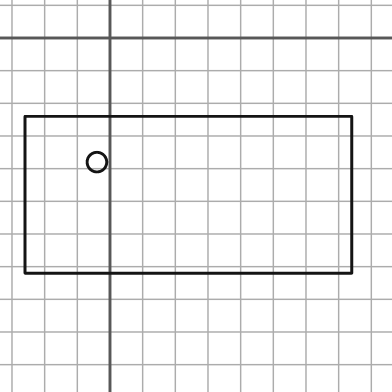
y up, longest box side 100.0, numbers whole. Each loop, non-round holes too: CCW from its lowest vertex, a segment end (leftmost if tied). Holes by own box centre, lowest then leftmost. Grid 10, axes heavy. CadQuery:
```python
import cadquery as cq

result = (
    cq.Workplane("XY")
    .moveTo(-26.0, -72.0)
    .lineTo(74.0, -72.0)
    .lineTo(74.0, -24.0)
    .lineTo(-26.0, -24.0)
    .close()
    .moveTo(-4.0, -38.0)
    .circle(3.0)
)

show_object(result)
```